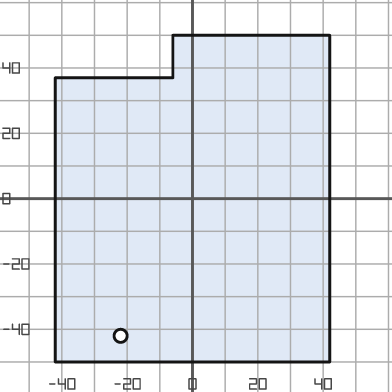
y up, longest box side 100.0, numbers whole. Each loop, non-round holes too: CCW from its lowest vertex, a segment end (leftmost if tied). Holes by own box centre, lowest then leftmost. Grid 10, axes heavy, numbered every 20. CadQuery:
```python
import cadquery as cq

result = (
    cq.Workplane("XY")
    .moveTo(-42.0, -50.0)
    .lineTo(42.0, -50.0)
    .lineTo(42.0, 50.0)
    .lineTo(-6.0, 50.0)
    .lineTo(-6.0, 37.0)
    .lineTo(-42.0, 37.0)
    .close()
    .moveTo(-22.0, -42.0)
    .circle(2.0)
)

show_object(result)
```